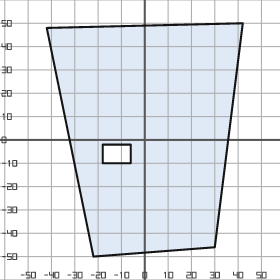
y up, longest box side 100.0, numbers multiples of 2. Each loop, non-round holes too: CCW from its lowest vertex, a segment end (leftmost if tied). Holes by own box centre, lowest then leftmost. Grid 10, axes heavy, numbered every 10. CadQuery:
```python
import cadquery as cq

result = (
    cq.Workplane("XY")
    .moveTo(-22.0, -50.0)
    .lineTo(30.0, -46.0)
    .lineTo(42.0, 50.0)
    .lineTo(-42.0, 48.0)
    .close()
    .moveTo(-18.0, -10.0)
    .lineTo(-6.0, -10.0)
    .lineTo(-6.0, -2.0)
    .lineTo(-18.0, -2.0)
    .close()
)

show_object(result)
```